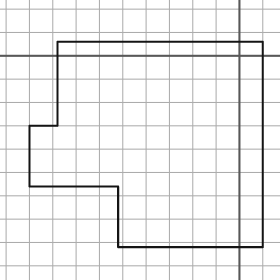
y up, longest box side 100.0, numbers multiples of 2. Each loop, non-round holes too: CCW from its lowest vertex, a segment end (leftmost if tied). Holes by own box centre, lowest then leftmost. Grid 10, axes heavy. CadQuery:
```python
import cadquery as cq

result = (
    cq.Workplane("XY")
    .moveTo(-52.0, -82.0)
    .lineTo(10.0, -82.0)
    .lineTo(10.0, 6.0)
    .lineTo(-78.0, 6.0)
    .lineTo(-78.0, -30.0)
    .lineTo(-90.0, -30.0)
    .lineTo(-90.0, -56.0)
    .lineTo(-52.0, -56.0)
    .close()
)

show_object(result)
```